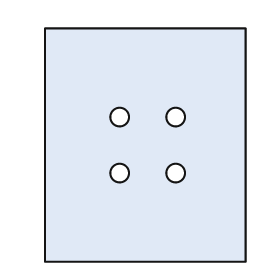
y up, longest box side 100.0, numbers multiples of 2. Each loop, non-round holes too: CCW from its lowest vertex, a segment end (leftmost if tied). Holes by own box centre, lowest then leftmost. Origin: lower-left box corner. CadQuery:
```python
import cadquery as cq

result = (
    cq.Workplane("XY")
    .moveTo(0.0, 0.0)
    .lineTo(86.0, 0.0)
    .lineTo(86.0, 100.0)
    .lineTo(0.0, 100.0)
    .close()
    .moveTo(32.0, 38.0)
    .circle(4.0)
    .moveTo(56.0, 38.0)
    .circle(4.0)
    .moveTo(32.0, 62.0)
    .circle(4.0)
    .moveTo(56.0, 62.0)
    .circle(4.0)
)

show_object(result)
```